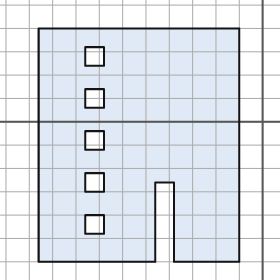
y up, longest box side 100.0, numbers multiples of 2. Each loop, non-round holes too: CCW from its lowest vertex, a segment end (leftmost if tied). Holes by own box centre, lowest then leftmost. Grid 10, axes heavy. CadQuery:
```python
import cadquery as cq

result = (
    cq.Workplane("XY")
    .moveTo(-96.0, -60.0)
    .lineTo(-46.0, -60.0)
    .lineTo(-46.0, -26.0)
    .lineTo(-38.0, -26.0)
    .lineTo(-38.0, -60.0)
    .lineTo(-10.0, -60.0)
    .lineTo(-10.0, 40.0)
    .lineTo(-96.0, 40.0)
    .close()
    .moveTo(-76.0, -48.0)
    .lineTo(-68.0, -48.0)
    .lineTo(-68.0, -40.0)
    .lineTo(-76.0, -40.0)
    .close()
    .moveTo(-76.0, -30.0)
    .lineTo(-68.0, -30.0)
    .lineTo(-68.0, -22.0)
    .lineTo(-76.0, -22.0)
    .close()
    .moveTo(-76.0, -12.0)
    .lineTo(-68.0, -12.0)
    .lineTo(-68.0, -4.0)
    .lineTo(-76.0, -4.0)
    .close()
    .moveTo(-76.0, 6.0)
    .lineTo(-68.0, 6.0)
    .lineTo(-68.0, 14.0)
    .lineTo(-76.0, 14.0)
    .close()
    .moveTo(-76.0, 24.0)
    .lineTo(-68.0, 24.0)
    .lineTo(-68.0, 32.0)
    .lineTo(-76.0, 32.0)
    .close()
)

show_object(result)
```